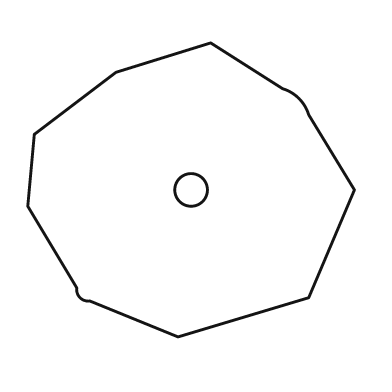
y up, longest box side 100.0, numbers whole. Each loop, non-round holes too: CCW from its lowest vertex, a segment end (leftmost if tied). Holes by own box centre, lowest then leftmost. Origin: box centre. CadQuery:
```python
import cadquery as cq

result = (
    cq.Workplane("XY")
    .moveTo(-4.0, -45.0)
    .lineTo(36.0, -33.0)
    .lineTo(50.0, 0.0)
    .lineTo(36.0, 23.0)
    .threePointArc((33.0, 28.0), (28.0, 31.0))
    .lineTo(6.0, 45.0)
    .lineTo(-23.0, 36.0)
    .lineTo(-48.0, 17.0)
    .lineTo(-50.0, -5.0)
    .lineTo(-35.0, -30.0)
    .threePointArc((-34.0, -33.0), (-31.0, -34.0))
    .close()
    .moveTo(0.0, 0.0)
    .circle(5.0)
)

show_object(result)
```